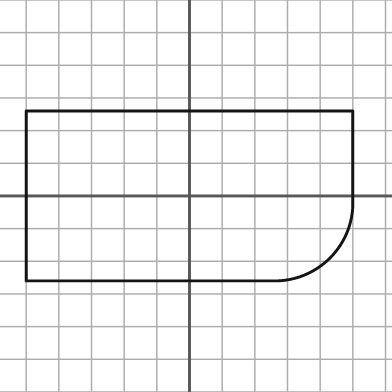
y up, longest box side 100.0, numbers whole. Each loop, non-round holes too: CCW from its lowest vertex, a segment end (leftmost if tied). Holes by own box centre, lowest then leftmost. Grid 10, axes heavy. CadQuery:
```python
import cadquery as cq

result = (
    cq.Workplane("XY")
    .moveTo(-50.0, -26.0)
    .lineTo(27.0, -26.0)
    .threePointArc((43.0, -19.0), (50.0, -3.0))
    .lineTo(50.0, 26.0)
    .lineTo(-50.0, 26.0)
    .close()
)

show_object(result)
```